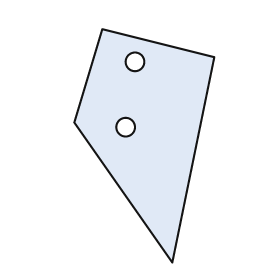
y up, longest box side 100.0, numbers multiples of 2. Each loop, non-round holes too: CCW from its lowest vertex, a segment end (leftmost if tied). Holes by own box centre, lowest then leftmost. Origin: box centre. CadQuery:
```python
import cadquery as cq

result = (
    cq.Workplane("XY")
    .moveTo(12.0, -50.0)
    .lineTo(30.0, 38.0)
    .lineTo(-18.0, 50.0)
    .lineTo(-30.0, 10.0)
    .close()
    .moveTo(-8.0, 8.0)
    .circle(4.0)
    .moveTo(-4.0, 36.0)
    .circle(4.0)
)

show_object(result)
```